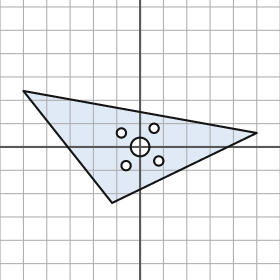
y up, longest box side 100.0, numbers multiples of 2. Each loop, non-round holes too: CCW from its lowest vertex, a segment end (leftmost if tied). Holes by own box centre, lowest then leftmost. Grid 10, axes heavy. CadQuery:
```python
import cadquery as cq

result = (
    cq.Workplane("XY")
    .moveTo(-12.0, -24.0)
    .lineTo(50.0, 6.0)
    .lineTo(-50.0, 24.0)
    .close()
    .moveTo(-6.0, -8.0)
    .circle(2.0)
    .moveTo(8.0, -6.0)
    .circle(2.0)
    .moveTo(0.0, 0.0)
    .circle(4.0)
    .moveTo(-8.0, 6.0)
    .circle(2.0)
    .moveTo(6.0, 8.0)
    .circle(2.0)
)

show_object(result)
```